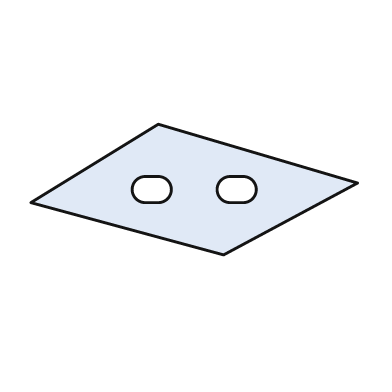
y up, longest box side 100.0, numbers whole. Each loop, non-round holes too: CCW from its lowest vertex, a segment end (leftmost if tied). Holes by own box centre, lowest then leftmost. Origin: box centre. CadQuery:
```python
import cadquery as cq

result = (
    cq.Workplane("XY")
    .moveTo(9.0, -20.0)
    .lineTo(50.0, 2.0)
    .lineTo(-11.0, 20.0)
    .lineTo(-50.0, -4.0)
    .close()
    .moveTo(-15.0, -4.0)
    .lineTo(-11.0, -4.0)
    .threePointArc((-7.0, 0.0), (-11.0, 4.0))
    .lineTo(-15.0, 4.0)
    .threePointArc((-19.0, 0.0), (-15.0, -4.0))
    .close()
    .moveTo(11.0, -4.0)
    .lineTo(15.0, -4.0)
    .threePointArc((19.0, 0.0), (15.0, 4.0))
    .lineTo(11.0, 4.0)
    .threePointArc((7.0, 0.0), (11.0, -4.0))
    .close()
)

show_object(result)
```